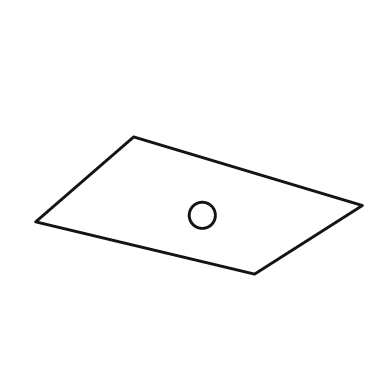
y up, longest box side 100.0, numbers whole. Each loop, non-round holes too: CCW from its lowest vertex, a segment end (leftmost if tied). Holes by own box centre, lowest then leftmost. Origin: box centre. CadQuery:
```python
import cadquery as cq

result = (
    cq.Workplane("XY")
    .moveTo(17.0, -21.0)
    .lineTo(50.0, 0.0)
    .lineTo(-20.0, 21.0)
    .lineTo(-50.0, -5.0)
    .close()
    .moveTo(1.0, -3.0)
    .circle(4.0)
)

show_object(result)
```